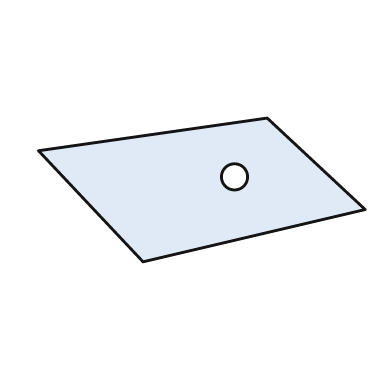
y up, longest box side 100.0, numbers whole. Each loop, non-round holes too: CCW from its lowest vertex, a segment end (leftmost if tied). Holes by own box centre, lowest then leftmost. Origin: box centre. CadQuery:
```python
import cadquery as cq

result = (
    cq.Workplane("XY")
    .moveTo(-18.0, -22.0)
    .lineTo(50.0, -6.0)
    .lineTo(20.0, 22.0)
    .lineTo(-50.0, 12.0)
    .close()
    .moveTo(10.0, 4.0)
    .circle(4.0)
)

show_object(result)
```